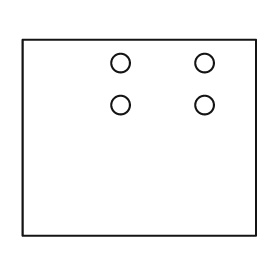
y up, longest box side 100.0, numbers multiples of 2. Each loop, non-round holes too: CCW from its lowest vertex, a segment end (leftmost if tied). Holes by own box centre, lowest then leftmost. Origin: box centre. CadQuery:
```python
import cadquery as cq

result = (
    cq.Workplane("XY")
    .moveTo(-50.0, -42.0)
    .lineTo(50.0, -42.0)
    .lineTo(50.0, 42.0)
    .lineTo(-50.0, 42.0)
    .close()
    .moveTo(-8.0, 14.0)
    .circle(4.0)
    .moveTo(28.0, 14.0)
    .circle(4.0)
    .moveTo(-8.0, 32.0)
    .circle(4.0)
    .moveTo(28.0, 32.0)
    .circle(4.0)
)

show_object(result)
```